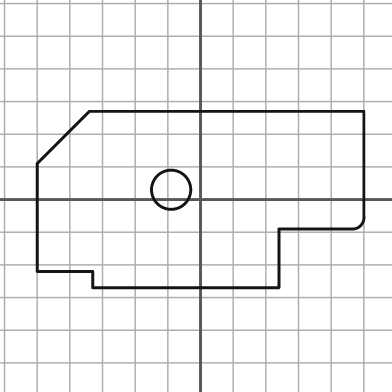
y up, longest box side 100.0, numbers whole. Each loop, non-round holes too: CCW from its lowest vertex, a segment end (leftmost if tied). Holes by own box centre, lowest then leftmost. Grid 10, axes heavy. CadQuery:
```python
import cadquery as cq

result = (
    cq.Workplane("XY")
    .moveTo(-33.0, -27.0)
    .lineTo(24.0, -27.0)
    .lineTo(24.0, -9.0)
    .lineTo(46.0, -9.0)
    .threePointArc((49.0, -8.0), (50.0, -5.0))
    .lineTo(50.0, 27.0)
    .lineTo(-34.0, 27.0)
    .lineTo(-50.0, 11.0)
    .lineTo(-50.0, -22.0)
    .lineTo(-33.0, -22.0)
    .close()
    .moveTo(-9.0, 3.0)
    .circle(6.0)
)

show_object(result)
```